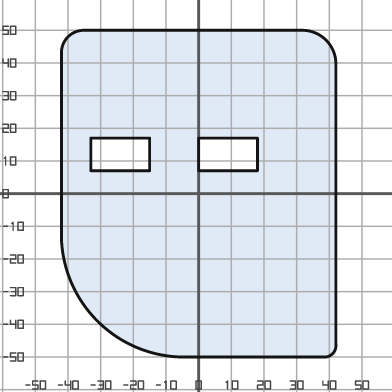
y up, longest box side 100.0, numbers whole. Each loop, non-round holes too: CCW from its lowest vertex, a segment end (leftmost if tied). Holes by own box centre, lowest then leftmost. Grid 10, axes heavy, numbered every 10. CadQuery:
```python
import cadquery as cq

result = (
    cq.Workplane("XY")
    .moveTo(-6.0, -50.0)
    .lineTo(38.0, -50.0)
    .threePointArc((41.0, -49.0), (42.0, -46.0))
    .lineTo(42.0, 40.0)
    .threePointArc((39.0, 47.0), (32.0, 50.0))
    .lineTo(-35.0, 50.0)
    .threePointArc((-40.0, 48.0), (-42.0, 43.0))
    .lineTo(-42.0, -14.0)
    .threePointArc((-31.0, -39.0), (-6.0, -50.0))
    .close()
    .moveTo(-33.0, 7.0)
    .lineTo(-15.0, 7.0)
    .lineTo(-15.0, 17.0)
    .lineTo(-33.0, 17.0)
    .close()
    .moveTo(0.0, 7.0)
    .lineTo(18.0, 7.0)
    .lineTo(18.0, 17.0)
    .lineTo(0.0, 17.0)
    .close()
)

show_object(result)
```